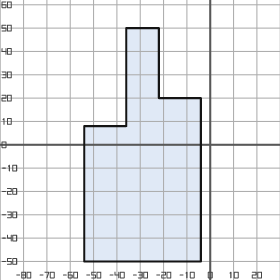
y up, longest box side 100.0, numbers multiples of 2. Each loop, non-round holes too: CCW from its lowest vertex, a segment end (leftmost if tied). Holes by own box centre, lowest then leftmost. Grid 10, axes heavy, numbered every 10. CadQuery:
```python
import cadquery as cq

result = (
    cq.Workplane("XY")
    .moveTo(-54.0, -50.0)
    .lineTo(-4.0, -50.0)
    .lineTo(-4.0, 20.0)
    .lineTo(-22.0, 20.0)
    .lineTo(-22.0, 50.0)
    .lineTo(-36.0, 50.0)
    .lineTo(-36.0, 8.0)
    .lineTo(-54.0, 8.0)
    .close()
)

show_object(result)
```